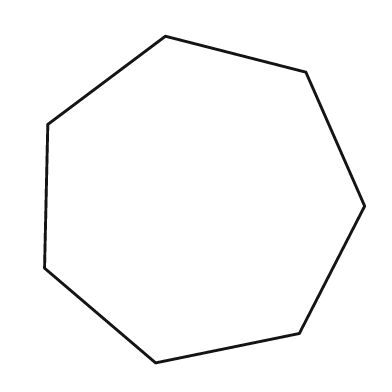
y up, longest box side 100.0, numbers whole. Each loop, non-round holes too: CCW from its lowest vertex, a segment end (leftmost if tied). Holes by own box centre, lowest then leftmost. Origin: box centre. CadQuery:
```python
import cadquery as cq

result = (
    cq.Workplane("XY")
    .moveTo(-15.0, -50.0)
    .lineTo(29.0, -41.0)
    .lineTo(49.0, -2.0)
    .lineTo(31.0, 39.0)
    .lineTo(-12.0, 50.0)
    .lineTo(-48.0, 23.0)
    .lineTo(-49.0, -21.0)
    .close()
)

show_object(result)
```